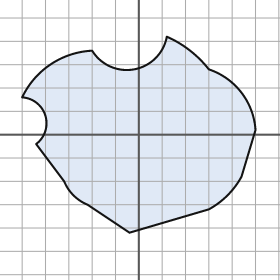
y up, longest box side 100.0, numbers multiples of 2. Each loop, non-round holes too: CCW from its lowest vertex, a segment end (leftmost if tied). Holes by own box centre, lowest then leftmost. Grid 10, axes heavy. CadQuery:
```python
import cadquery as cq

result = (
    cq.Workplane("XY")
    .moveTo(-4.0, -42.0)
    .lineTo(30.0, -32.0)
    .threePointArc((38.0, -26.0), (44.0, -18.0))
    .lineTo(50.0, 2.0)
    .threePointArc((44.0, 18.0), (30.0, 28.0))
    .threePointArc((22.0, 36.0), (12.0, 42.0))
    .threePointArc((-2.0, 28.0), (-20.0, 36.0))
    .threePointArc((-38.0, 30.0), (-50.0, 16.0))
    .threePointArc((-40.0, 8.0), (-44.0, -4.0))
    .lineTo(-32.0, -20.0)
    .threePointArc((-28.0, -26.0), (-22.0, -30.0))
    .close()
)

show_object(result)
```